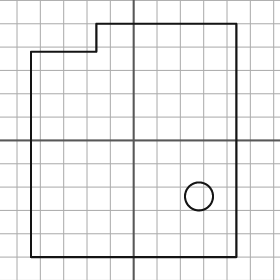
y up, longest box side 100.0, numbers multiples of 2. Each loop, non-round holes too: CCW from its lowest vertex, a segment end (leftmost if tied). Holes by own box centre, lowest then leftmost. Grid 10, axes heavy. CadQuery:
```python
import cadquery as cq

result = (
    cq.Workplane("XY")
    .moveTo(-44.0, -50.0)
    .lineTo(44.0, -50.0)
    .lineTo(44.0, 50.0)
    .lineTo(-16.0, 50.0)
    .lineTo(-16.0, 38.0)
    .lineTo(-44.0, 38.0)
    .close()
    .moveTo(28.0, -24.0)
    .circle(6.0)
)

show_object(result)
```